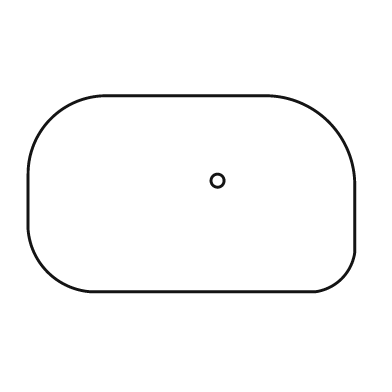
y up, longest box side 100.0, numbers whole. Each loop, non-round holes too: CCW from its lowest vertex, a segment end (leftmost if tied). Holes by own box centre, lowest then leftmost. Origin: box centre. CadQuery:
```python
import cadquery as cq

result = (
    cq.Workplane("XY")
    .moveTo(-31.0, -30.0)
    .lineTo(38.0, -30.0)
    .threePointArc((46.0, -26.0), (50.0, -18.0))
    .lineTo(50.0, 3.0)
    .threePointArc((42.0, 22.0), (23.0, 30.0))
    .lineTo(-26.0, 30.0)
    .threePointArc((-43.0, 23.0), (-50.0, 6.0))
    .lineTo(-50.0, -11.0)
    .threePointArc((-44.0, -24.0), (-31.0, -30.0))
    .close()
    .moveTo(8.0, 4.0)
    .circle(2.0)
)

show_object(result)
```